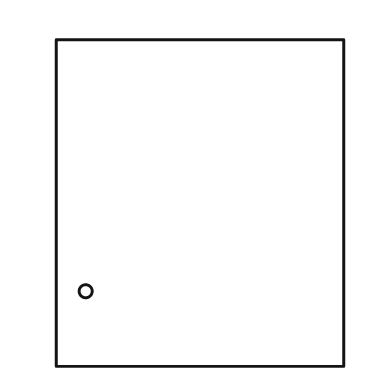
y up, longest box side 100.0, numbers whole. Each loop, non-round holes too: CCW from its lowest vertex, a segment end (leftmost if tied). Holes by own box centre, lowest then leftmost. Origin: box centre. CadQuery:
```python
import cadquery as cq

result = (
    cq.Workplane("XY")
    .moveTo(-44.0, -50.0)
    .lineTo(44.0, -50.0)
    .lineTo(44.0, 50.0)
    .lineTo(-44.0, 50.0)
    .close()
    .moveTo(-35.0, -27.0)
    .circle(2.0)
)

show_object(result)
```